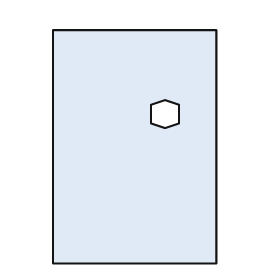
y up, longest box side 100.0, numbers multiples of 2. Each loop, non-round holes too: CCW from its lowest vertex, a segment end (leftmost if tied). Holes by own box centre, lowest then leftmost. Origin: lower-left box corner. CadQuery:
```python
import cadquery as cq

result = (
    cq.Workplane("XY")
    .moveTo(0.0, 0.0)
    .lineTo(70.0, 0.0)
    .lineTo(70.0, 100.0)
    .lineTo(0.0, 100.0)
    .close()
    .moveTo(48.0, 58.0)
    .lineTo(54.0, 60.0)
    .lineTo(54.0, 68.0)
    .lineTo(48.0, 70.0)
    .lineTo(42.0, 68.0)
    .lineTo(42.0, 60.0)
    .close()
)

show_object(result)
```